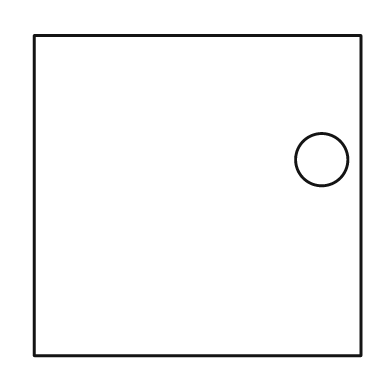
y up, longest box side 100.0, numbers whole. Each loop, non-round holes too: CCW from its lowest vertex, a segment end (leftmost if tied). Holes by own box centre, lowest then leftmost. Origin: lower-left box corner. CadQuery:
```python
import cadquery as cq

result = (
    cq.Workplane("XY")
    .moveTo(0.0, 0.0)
    .lineTo(100.0, 0.0)
    .lineTo(100.0, 98.0)
    .lineTo(0.0, 98.0)
    .close()
    .moveTo(88.0, 60.0)
    .circle(8.0)
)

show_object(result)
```